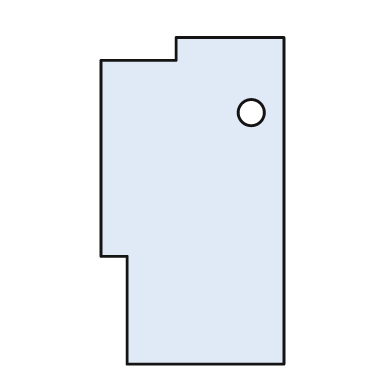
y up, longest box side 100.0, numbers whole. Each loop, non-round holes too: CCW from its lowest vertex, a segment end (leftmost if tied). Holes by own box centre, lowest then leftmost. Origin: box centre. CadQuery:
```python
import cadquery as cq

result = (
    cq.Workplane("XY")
    .moveTo(-20.0, -50.0)
    .lineTo(28.0, -50.0)
    .lineTo(28.0, 50.0)
    .lineTo(-5.0, 50.0)
    .lineTo(-5.0, 43.0)
    .lineTo(-28.0, 43.0)
    .lineTo(-28.0, -17.0)
    .lineTo(-20.0, -17.0)
    .close()
    .moveTo(18.0, 27.0)
    .circle(4.0)
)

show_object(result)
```